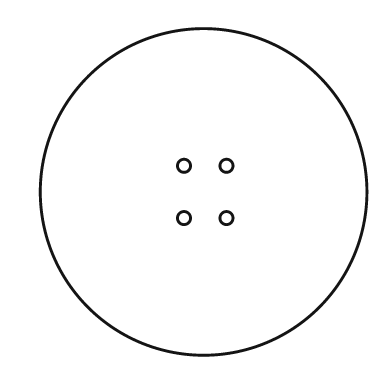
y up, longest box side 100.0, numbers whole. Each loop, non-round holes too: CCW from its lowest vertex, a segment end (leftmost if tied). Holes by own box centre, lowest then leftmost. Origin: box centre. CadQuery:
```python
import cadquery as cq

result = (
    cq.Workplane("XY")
    .moveTo(0.0, 0.0)
    .circle(50.0)
    .moveTo(-6.0, -8.0)
    .circle(2.0)
    .moveTo(7.0, -8.0)
    .circle(2.0)
    .moveTo(-6.0, 8.0)
    .circle(2.0)
    .moveTo(7.0, 8.0)
    .circle(2.0)
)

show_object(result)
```